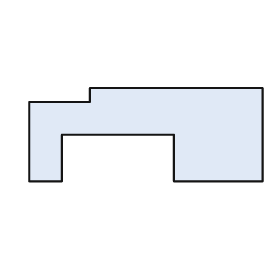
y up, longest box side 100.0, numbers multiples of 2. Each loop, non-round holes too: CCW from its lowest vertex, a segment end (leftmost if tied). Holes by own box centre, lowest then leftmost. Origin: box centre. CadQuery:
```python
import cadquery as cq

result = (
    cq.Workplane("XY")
    .moveTo(-50.0, -20.0)
    .lineTo(-36.0, -20.0)
    .lineTo(-36.0, 0.0)
    .lineTo(12.0, 0.0)
    .lineTo(12.0, -20.0)
    .lineTo(50.0, -20.0)
    .lineTo(50.0, 20.0)
    .lineTo(-24.0, 20.0)
    .lineTo(-24.0, 14.0)
    .lineTo(-50.0, 14.0)
    .close()
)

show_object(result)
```